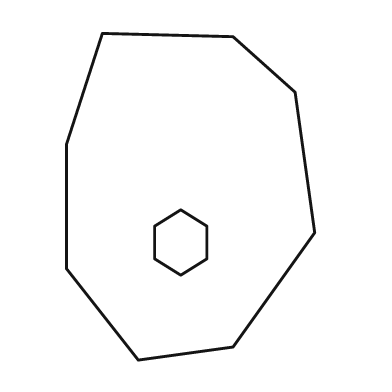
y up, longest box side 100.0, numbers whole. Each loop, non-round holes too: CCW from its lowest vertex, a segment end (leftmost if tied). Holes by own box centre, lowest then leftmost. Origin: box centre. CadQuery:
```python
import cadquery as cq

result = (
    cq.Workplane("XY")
    .moveTo(-16.0, -50.0)
    .lineTo(13.0, -46.0)
    .lineTo(38.0, -11.0)
    .lineTo(32.0, 32.0)
    .lineTo(13.0, 49.0)
    .lineTo(-27.0, 50.0)
    .lineTo(-38.0, 16.0)
    .lineTo(-38.0, -22.0)
    .close()
    .moveTo(-3.0, -24.0)
    .lineTo(5.0, -19.0)
    .lineTo(5.0, -9.0)
    .lineTo(-3.0, -4.0)
    .lineTo(-11.0, -9.0)
    .lineTo(-11.0, -19.0)
    .close()
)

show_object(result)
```